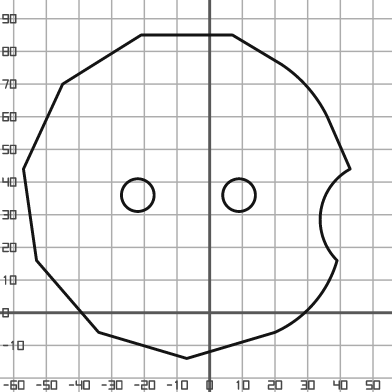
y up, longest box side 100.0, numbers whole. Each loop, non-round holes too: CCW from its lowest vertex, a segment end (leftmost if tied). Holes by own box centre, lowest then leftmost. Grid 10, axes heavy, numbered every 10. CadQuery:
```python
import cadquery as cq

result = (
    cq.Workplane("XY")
    .moveTo(-7.0, -14.0)
    .lineTo(20.0, -6.0)
    .threePointArc((32.0, 3.0), (39.0, 16.0))
    .threePointArc((34.0, 31.0), (43.0, 44.0))
    .lineTo(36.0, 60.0)
    .threePointArc((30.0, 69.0), (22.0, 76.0))
    .lineTo(7.0, 85.0)
    .lineTo(-21.0, 85.0)
    .lineTo(-45.0, 70.0)
    .lineTo(-57.0, 44.0)
    .lineTo(-53.0, 16.0)
    .lineTo(-34.0, -6.0)
    .close()
    .moveTo(-22.0, 36.0)
    .circle(5.0)
    .moveTo(9.0, 36.0)
    .circle(5.0)
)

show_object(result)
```